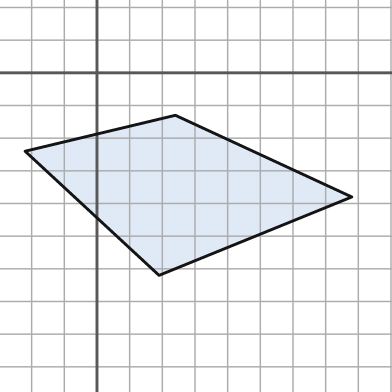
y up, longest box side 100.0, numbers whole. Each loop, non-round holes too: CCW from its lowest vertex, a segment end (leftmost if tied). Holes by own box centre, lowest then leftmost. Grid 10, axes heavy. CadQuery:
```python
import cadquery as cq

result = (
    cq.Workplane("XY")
    .moveTo(19.0, -62.0)
    .lineTo(78.0, -38.0)
    .lineTo(24.0, -13.0)
    .lineTo(-22.0, -24.0)
    .close()
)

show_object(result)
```